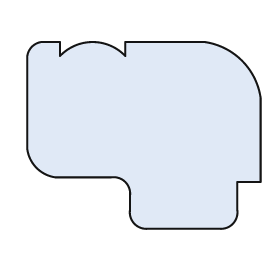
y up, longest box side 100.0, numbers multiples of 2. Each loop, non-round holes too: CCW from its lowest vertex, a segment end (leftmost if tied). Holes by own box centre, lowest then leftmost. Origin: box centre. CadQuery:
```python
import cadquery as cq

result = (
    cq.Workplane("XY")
    .moveTo(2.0, -40.0)
    .lineTo(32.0, -40.0)
    .threePointArc((38.0, -38.0), (40.0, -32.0))
    .lineTo(40.0, -20.0)
    .lineTo(50.0, -20.0)
    .lineTo(50.0, 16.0)
    .threePointArc((42.0, 32.0), (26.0, 40.0))
    .lineTo(-8.0, 40.0)
    .lineTo(-8.0, 34.0)
    .threePointArc((-22.0, 40.0), (-36.0, 34.0))
    .lineTo(-36.0, 40.0)
    .lineTo(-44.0, 40.0)
    .threePointArc((-48.0, 38.0), (-50.0, 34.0))
    .lineTo(-50.0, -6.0)
    .threePointArc((-46.0, -14.0), (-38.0, -18.0))
    .lineTo(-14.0, -18.0)
    .threePointArc((-8.0, -20.0), (-6.0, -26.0))
    .lineTo(-6.0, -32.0)
    .threePointArc((-4.0, -38.0), (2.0, -40.0))
    .close()
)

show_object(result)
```